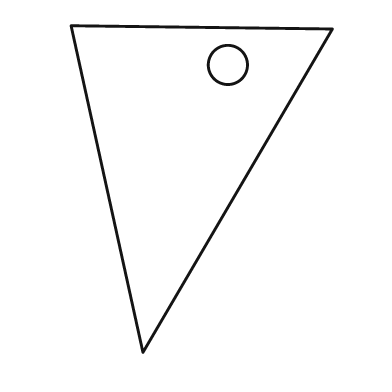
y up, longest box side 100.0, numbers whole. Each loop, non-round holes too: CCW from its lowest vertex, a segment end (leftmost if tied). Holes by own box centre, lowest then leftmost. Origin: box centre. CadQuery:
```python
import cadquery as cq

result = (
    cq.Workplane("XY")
    .moveTo(-18.0, -50.0)
    .lineTo(40.0, 49.0)
    .lineTo(-40.0, 50.0)
    .close()
    .moveTo(8.0, 38.0)
    .circle(6.0)
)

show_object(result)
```